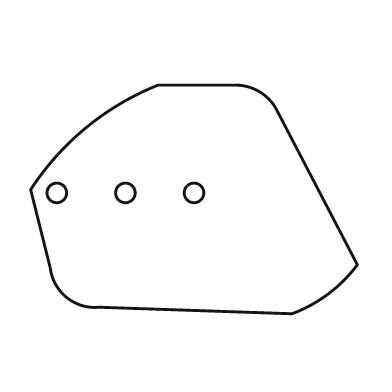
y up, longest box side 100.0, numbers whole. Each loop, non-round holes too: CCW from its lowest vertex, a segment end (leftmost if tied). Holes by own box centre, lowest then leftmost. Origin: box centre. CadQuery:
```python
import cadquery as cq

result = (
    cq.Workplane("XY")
    .moveTo(30.0, -35.0)
    .threePointArc((41.0, -29.0), (50.0, -20.0))
    .lineTo(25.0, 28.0)
    .threePointArc((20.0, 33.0), (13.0, 35.0))
    .lineTo(-11.0, 35.0)
    .threePointArc((-33.0, 22.0), (-50.0, 3.0))
    .lineTo(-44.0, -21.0)
    .threePointArc((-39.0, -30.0), (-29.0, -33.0))
    .close()
    .moveTo(-42.0, 2.0)
    .circle(3.0)
    .moveTo(-21.0, 2.0)
    .circle(3.0)
    .moveTo(0.0, 2.0)
    .circle(3.0)
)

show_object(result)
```